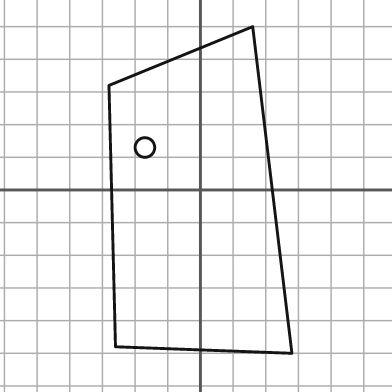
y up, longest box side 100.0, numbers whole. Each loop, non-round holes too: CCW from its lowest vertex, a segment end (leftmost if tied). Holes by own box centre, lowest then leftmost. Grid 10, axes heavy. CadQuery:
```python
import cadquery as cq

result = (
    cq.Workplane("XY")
    .moveTo(28.0, -50.0)
    .lineTo(16.0, 50.0)
    .lineTo(-28.0, 32.0)
    .lineTo(-26.0, -48.0)
    .close()
    .moveTo(-17.0, 13.0)
    .circle(3.0)
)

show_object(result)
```